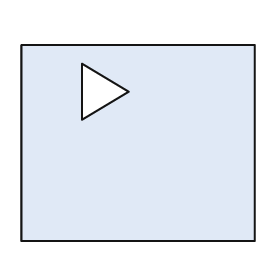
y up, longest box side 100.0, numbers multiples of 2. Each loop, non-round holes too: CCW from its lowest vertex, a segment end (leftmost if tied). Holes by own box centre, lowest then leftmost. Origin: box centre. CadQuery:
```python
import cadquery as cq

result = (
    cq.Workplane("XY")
    .moveTo(-50.0, -42.0)
    .lineTo(50.0, -42.0)
    .lineTo(50.0, 42.0)
    .lineTo(-50.0, 42.0)
    .close()
    .moveTo(-24.0, 10.0)
    .lineTo(-4.0, 22.0)
    .lineTo(-24.0, 34.0)
    .close()
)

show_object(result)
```